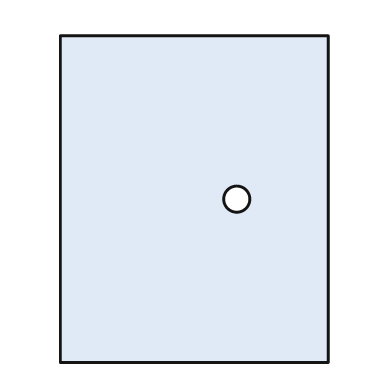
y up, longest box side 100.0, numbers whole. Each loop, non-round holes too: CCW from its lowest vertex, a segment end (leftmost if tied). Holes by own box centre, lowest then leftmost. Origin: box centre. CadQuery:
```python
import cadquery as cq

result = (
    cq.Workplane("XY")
    .moveTo(-41.0, -50.0)
    .lineTo(41.0, -50.0)
    .lineTo(41.0, 50.0)
    .lineTo(-41.0, 50.0)
    .close()
    .moveTo(13.0, 0.0)
    .circle(4.0)
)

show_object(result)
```